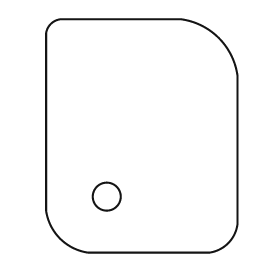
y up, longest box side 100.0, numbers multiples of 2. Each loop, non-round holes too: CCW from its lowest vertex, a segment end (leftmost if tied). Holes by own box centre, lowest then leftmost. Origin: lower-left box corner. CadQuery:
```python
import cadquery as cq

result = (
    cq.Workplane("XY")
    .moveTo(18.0, 0.0)
    .lineTo(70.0, 0.0)
    .threePointArc((78.0, 4.0), (82.0, 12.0))
    .lineTo(82.0, 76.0)
    .threePointArc((74.0, 92.0), (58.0, 100.0))
    .lineTo(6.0, 100.0)
    .threePointArc((2.0, 98.0), (0.0, 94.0))
    .lineTo(0.0, 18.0)
    .threePointArc((6.0, 6.0), (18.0, 0.0))
    .close()
    .moveTo(26.0, 24.0)
    .circle(6.0)
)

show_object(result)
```